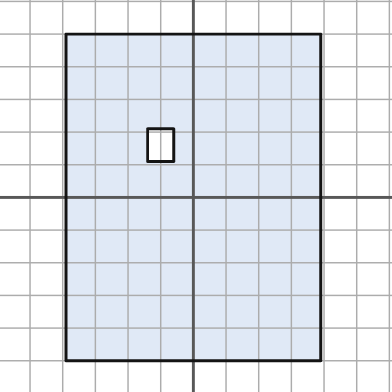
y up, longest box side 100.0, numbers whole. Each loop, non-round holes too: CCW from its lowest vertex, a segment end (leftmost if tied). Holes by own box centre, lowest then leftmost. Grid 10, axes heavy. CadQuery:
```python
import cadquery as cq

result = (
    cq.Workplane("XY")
    .moveTo(-39.0, -50.0)
    .lineTo(39.0, -50.0)
    .lineTo(39.0, 50.0)
    .lineTo(-39.0, 50.0)
    .close()
    .moveTo(-14.0, 11.0)
    .lineTo(-6.0, 11.0)
    .lineTo(-6.0, 21.0)
    .lineTo(-14.0, 21.0)
    .close()
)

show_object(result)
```